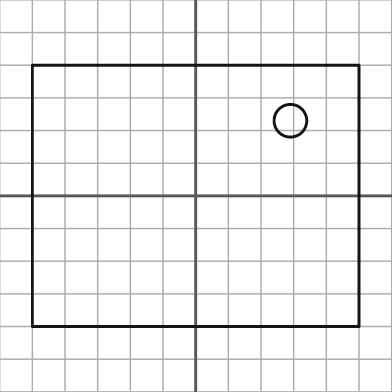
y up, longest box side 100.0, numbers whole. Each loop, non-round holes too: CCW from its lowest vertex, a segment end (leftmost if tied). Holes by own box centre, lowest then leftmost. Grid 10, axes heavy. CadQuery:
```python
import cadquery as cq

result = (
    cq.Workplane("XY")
    .moveTo(-50.0, -40.0)
    .lineTo(50.0, -40.0)
    .lineTo(50.0, 40.0)
    .lineTo(-50.0, 40.0)
    .close()
    .moveTo(29.0, 23.0)
    .circle(5.0)
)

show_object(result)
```